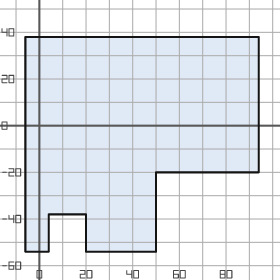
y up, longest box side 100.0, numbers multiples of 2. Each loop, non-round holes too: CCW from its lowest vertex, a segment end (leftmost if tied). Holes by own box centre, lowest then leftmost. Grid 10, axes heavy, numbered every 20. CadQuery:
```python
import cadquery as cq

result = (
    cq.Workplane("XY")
    .moveTo(-6.0, -54.0)
    .lineTo(4.0, -54.0)
    .lineTo(4.0, -38.0)
    .lineTo(20.0, -38.0)
    .lineTo(20.0, -54.0)
    .lineTo(50.0, -54.0)
    .lineTo(50.0, -20.0)
    .lineTo(94.0, -20.0)
    .lineTo(94.0, 38.0)
    .lineTo(-6.0, 38.0)
    .close()
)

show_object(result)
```